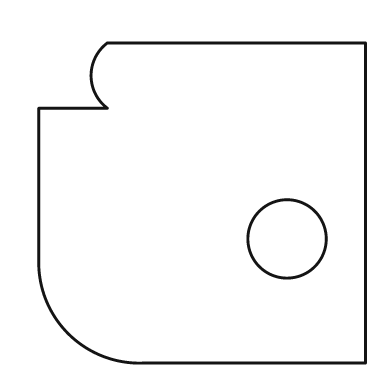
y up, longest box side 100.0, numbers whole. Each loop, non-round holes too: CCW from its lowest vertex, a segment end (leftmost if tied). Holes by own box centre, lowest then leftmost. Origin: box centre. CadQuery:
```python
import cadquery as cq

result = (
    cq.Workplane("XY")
    .moveTo(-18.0, -49.0)
    .lineTo(50.0, -49.0)
    .lineTo(50.0, 49.0)
    .lineTo(-29.0, 49.0)
    .threePointArc((-34.0, 39.0), (-29.0, 29.0))
    .lineTo(-50.0, 29.0)
    .lineTo(-50.0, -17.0)
    .threePointArc((-41.0, -40.0), (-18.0, -49.0))
    .close()
    .moveTo(26.0, -11.0)
    .circle(12.0)
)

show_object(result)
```